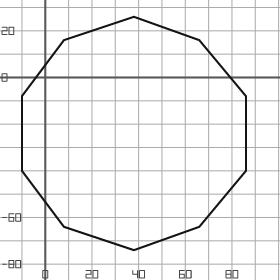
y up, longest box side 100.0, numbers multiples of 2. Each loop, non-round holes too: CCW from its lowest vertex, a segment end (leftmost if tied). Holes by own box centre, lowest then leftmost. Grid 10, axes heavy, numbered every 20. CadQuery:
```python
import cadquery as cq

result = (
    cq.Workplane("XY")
    .moveTo(38.0, -74.0)
    .lineTo(66.0, -64.0)
    .lineTo(86.0, -40.0)
    .lineTo(86.0, -8.0)
    .lineTo(66.0, 16.0)
    .lineTo(38.0, 26.0)
    .lineTo(8.0, 16.0)
    .lineTo(-10.0, -8.0)
    .lineTo(-10.0, -40.0)
    .lineTo(8.0, -64.0)
    .close()
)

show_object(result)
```